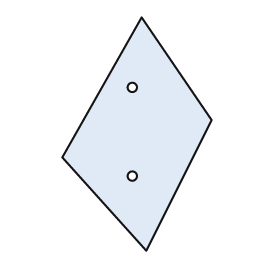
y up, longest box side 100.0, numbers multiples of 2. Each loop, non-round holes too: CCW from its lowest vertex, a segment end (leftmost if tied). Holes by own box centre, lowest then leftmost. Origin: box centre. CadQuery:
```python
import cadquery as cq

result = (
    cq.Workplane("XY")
    .moveTo(4.0, -50.0)
    .lineTo(32.0, 6.0)
    .lineTo(2.0, 50.0)
    .lineTo(-32.0, -10.0)
    .close()
    .moveTo(-2.0, -18.0)
    .circle(2.0)
    .moveTo(-2.0, 20.0)
    .circle(2.0)
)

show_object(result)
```